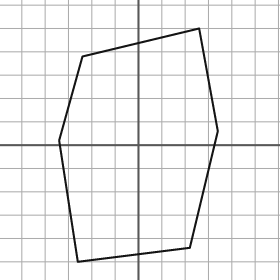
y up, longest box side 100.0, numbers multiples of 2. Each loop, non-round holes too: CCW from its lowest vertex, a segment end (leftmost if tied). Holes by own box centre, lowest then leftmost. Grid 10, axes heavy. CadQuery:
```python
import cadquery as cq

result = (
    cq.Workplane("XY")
    .moveTo(-26.0, -50.0)
    .lineTo(22.0, -44.0)
    .lineTo(34.0, 6.0)
    .lineTo(26.0, 50.0)
    .lineTo(-24.0, 38.0)
    .lineTo(-34.0, 2.0)
    .close()
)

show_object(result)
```